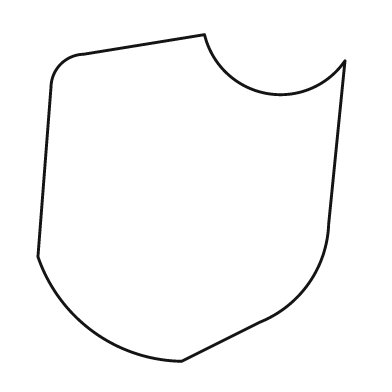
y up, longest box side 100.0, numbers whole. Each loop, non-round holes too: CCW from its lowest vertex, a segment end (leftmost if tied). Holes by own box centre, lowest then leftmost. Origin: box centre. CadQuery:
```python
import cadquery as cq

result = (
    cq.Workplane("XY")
    .moveTo(-3.0, -50.0)
    .lineTo(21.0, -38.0)
    .threePointArc((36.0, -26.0), (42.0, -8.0))
    .lineTo(47.0, 42.0)
    .threePointArc((23.0, 32.0), (4.0, 50.0))
    .lineTo(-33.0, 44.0)
    .threePointArc((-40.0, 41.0), (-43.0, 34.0))
    .lineTo(-47.0, -18.0)
    .threePointArc((-30.0, -41.0), (-3.0, -50.0))
    .close()
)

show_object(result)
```